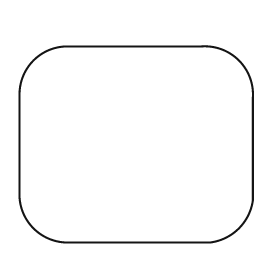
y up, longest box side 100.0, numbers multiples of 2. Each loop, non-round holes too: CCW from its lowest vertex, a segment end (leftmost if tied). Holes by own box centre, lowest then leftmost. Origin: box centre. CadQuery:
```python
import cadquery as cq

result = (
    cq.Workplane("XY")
    .moveTo(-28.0, -42.0)
    .lineTo(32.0, -42.0)
    .threePointArc((44.0, -36.0), (50.0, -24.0))
    .lineTo(50.0, 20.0)
    .threePointArc((44.0, 36.0), (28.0, 42.0))
    .lineTo(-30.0, 42.0)
    .threePointArc((-44.0, 36.0), (-50.0, 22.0))
    .lineTo(-50.0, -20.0)
    .threePointArc((-44.0, -36.0), (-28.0, -42.0))
    .close()
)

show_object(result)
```